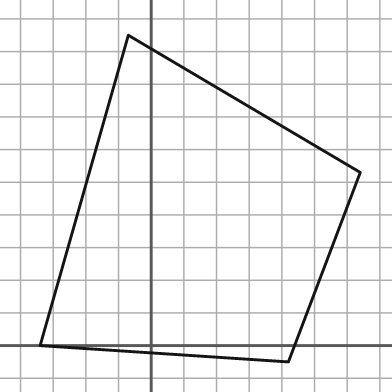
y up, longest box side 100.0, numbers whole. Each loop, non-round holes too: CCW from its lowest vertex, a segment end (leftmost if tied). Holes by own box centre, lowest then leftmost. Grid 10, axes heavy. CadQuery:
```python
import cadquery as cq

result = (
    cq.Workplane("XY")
    .moveTo(42.0, -5.0)
    .lineTo(64.0, 53.0)
    .lineTo(-7.0, 95.0)
    .lineTo(-34.0, 0.0)
    .close()
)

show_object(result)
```